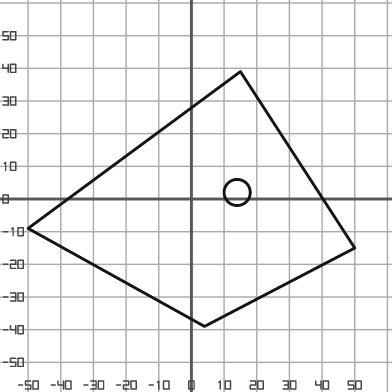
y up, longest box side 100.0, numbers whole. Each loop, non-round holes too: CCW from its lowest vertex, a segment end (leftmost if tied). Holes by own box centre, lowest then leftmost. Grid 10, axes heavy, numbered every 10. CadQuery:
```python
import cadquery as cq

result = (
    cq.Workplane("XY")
    .moveTo(4.0, -39.0)
    .lineTo(50.0, -15.0)
    .lineTo(15.0, 39.0)
    .lineTo(-50.0, -9.0)
    .close()
    .moveTo(14.0, 2.0)
    .circle(4.0)
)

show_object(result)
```